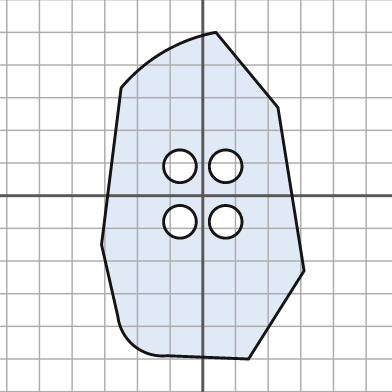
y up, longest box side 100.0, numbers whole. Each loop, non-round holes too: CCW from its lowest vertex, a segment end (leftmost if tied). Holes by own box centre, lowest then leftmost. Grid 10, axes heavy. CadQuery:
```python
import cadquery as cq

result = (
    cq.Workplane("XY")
    .moveTo(14.0, -50.0)
    .lineTo(31.0, -23.0)
    .lineTo(23.0, 27.0)
    .lineTo(4.0, 50.0)
    .threePointArc((-12.0, 44.0), (-25.0, 33.0))
    .lineTo(-31.0, -15.0)
    .lineTo(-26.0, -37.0)
    .threePointArc((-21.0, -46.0), (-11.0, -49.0))
    .close()
    .moveTo(-7.0, -8.0)
    .circle(5.0)
    .moveTo(7.0, -8.0)
    .circle(5.0)
    .moveTo(-7.0, 9.0)
    .circle(5.0)
    .moveTo(7.0, 9.0)
    .circle(5.0)
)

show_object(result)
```